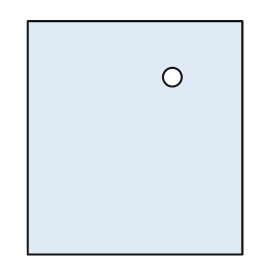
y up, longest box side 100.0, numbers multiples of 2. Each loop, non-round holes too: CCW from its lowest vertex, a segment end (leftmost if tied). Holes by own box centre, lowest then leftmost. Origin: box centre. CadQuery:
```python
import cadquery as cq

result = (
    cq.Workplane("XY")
    .moveTo(-46.0, -50.0)
    .lineTo(46.0, -50.0)
    .lineTo(46.0, 50.0)
    .lineTo(-46.0, 50.0)
    .close()
    .moveTo(16.0, 26.0)
    .circle(4.0)
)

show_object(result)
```